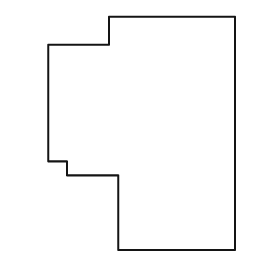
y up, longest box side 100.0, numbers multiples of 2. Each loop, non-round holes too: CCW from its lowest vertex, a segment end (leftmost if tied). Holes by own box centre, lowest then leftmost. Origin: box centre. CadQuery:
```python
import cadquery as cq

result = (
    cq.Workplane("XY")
    .moveTo(-10.0, -50.0)
    .lineTo(40.0, -50.0)
    .lineTo(40.0, 50.0)
    .lineTo(-14.0, 50.0)
    .lineTo(-14.0, 38.0)
    .lineTo(-40.0, 38.0)
    .lineTo(-40.0, -12.0)
    .lineTo(-32.0, -12.0)
    .lineTo(-32.0, -18.0)
    .lineTo(-10.0, -18.0)
    .close()
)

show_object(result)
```